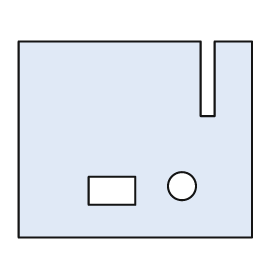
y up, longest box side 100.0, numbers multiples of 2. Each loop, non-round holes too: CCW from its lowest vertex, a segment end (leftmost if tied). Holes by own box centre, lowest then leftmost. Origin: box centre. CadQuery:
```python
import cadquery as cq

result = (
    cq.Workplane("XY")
    .moveTo(-50.0, -42.0)
    .lineTo(50.0, -42.0)
    .lineTo(50.0, 42.0)
    .lineTo(34.0, 42.0)
    .lineTo(34.0, 10.0)
    .lineTo(28.0, 10.0)
    .lineTo(28.0, 42.0)
    .lineTo(-50.0, 42.0)
    .close()
    .moveTo(-20.0, -28.0)
    .lineTo(0.0, -28.0)
    .lineTo(0.0, -16.0)
    .lineTo(-20.0, -16.0)
    .close()
    .moveTo(20.0, -20.0)
    .circle(6.0)
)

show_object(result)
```